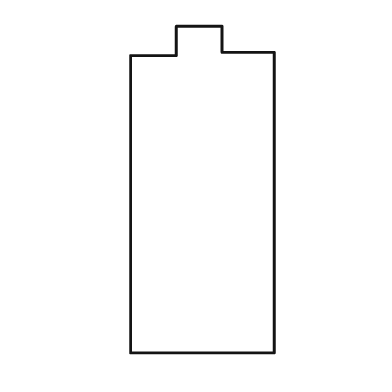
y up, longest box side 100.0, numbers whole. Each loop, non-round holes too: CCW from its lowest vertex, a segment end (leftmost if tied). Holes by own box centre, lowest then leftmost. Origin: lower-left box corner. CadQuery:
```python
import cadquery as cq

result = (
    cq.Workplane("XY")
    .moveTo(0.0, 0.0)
    .lineTo(44.0, 0.0)
    .lineTo(44.0, 92.0)
    .lineTo(28.0, 92.0)
    .lineTo(28.0, 100.0)
    .lineTo(14.0, 100.0)
    .lineTo(14.0, 91.0)
    .lineTo(0.0, 91.0)
    .close()
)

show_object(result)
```